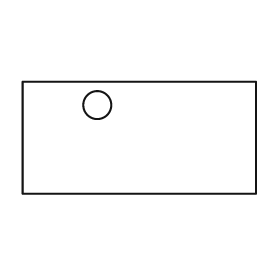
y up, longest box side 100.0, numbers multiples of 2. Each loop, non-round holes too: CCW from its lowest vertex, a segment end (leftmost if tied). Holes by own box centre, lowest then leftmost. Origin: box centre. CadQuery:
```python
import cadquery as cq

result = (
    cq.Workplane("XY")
    .moveTo(-50.0, -24.0)
    .lineTo(50.0, -24.0)
    .lineTo(50.0, 24.0)
    .lineTo(-50.0, 24.0)
    .close()
    .moveTo(-18.0, 14.0)
    .circle(6.0)
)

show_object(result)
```